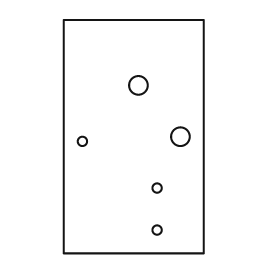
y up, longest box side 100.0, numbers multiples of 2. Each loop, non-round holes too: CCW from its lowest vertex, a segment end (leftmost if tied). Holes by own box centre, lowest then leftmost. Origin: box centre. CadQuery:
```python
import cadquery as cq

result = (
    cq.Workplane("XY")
    .moveTo(-30.0, -50.0)
    .lineTo(30.0, -50.0)
    .lineTo(30.0, 50.0)
    .lineTo(-30.0, 50.0)
    .close()
    .moveTo(10.0, -40.0)
    .circle(2.0)
    .moveTo(10.0, -22.0)
    .circle(2.0)
    .moveTo(-22.0, -2.0)
    .circle(2.0)
    .moveTo(20.0, 0.0)
    .circle(4.0)
    .moveTo(2.0, 22.0)
    .circle(4.0)
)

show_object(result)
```